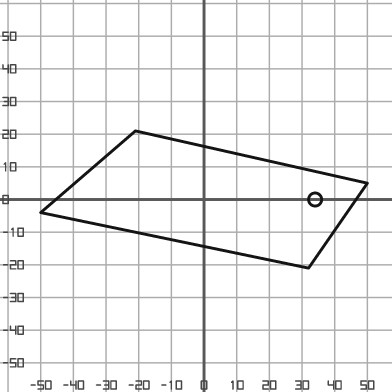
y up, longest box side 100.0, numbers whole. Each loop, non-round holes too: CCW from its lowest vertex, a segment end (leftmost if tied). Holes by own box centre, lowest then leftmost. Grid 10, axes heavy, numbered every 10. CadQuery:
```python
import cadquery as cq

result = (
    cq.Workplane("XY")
    .moveTo(32.0, -21.0)
    .lineTo(50.0, 5.0)
    .lineTo(-21.0, 21.0)
    .lineTo(-50.0, -4.0)
    .close()
    .moveTo(34.0, 0.0)
    .circle(2.0)
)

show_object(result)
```